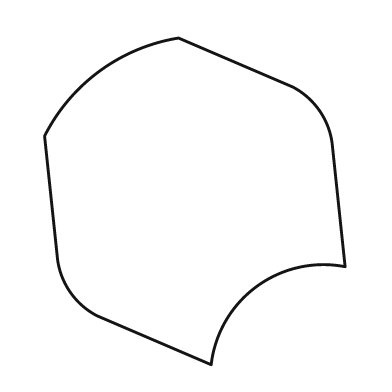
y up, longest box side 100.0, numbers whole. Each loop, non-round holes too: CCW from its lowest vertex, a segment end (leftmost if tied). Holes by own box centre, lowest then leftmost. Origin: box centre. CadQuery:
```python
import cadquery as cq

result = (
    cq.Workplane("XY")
    .moveTo(5.0, -50.0)
    .threePointArc((19.0, -26.0), (46.0, -20.0))
    .lineTo(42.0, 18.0)
    .threePointArc((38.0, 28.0), (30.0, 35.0))
    .lineTo(-5.0, 50.0)
    .threePointArc((-29.0, 40.0), (-46.0, 20.0))
    .lineTo(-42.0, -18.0)
    .threePointArc((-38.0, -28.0), (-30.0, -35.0))
    .close()
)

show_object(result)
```